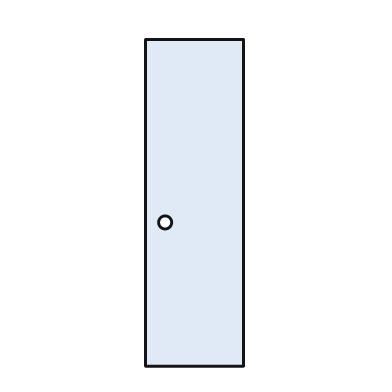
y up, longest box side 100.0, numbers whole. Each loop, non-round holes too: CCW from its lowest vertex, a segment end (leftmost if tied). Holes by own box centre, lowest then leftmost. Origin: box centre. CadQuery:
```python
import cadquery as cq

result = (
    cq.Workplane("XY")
    .moveTo(-15.0, -50.0)
    .lineTo(15.0, -50.0)
    .lineTo(15.0, 50.0)
    .lineTo(-15.0, 50.0)
    .close()
    .moveTo(-9.0, -6.0)
    .circle(2.0)
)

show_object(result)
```